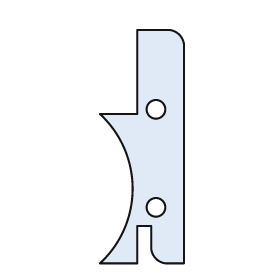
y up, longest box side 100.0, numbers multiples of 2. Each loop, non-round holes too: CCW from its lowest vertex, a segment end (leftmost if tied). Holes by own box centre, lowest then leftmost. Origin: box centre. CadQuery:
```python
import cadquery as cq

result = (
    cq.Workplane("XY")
    .moveTo(-18.0, -50.0)
    .lineTo(-2.0, -50.0)
    .lineTo(-2.0, -34.0)
    .lineTo(4.0, -34.0)
    .lineTo(4.0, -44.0)
    .threePointArc((6.0, -48.0), (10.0, -50.0))
    .lineTo(18.0, -50.0)
    .lineTo(18.0, 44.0)
    .threePointArc((16.0, 48.0), (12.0, 50.0))
    .lineTo(-2.0, 50.0)
    .lineTo(-2.0, 14.0)
    .lineTo(-18.0, 14.0)
    .threePointArc((-4.0, -18.0), (-18.0, -50.0))
    .close()
    .moveTo(6.0, -26.0)
    .circle(4.0)
    .moveTo(6.0, 16.0)
    .circle(4.0)
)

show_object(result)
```